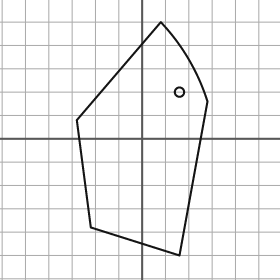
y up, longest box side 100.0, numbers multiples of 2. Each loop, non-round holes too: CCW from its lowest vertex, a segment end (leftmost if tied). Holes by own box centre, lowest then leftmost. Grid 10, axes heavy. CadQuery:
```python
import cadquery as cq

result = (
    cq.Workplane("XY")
    .moveTo(16.0, -50.0)
    .lineTo(28.0, 16.0)
    .threePointArc((20.0, 34.0), (8.0, 50.0))
    .lineTo(-28.0, 8.0)
    .lineTo(-22.0, -38.0)
    .close()
    .moveTo(16.0, 20.0)
    .circle(2.0)
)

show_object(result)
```